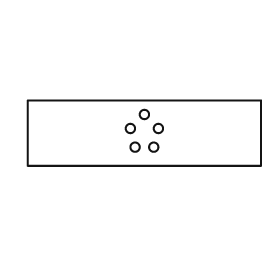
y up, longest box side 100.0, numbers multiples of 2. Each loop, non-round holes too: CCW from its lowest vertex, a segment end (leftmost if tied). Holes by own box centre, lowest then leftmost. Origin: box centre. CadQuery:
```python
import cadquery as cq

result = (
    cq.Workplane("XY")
    .moveTo(-50.0, -14.0)
    .lineTo(50.0, -14.0)
    .lineTo(50.0, 14.0)
    .lineTo(-50.0, 14.0)
    .close()
    .moveTo(-4.0, -6.0)
    .circle(2.0)
    .moveTo(4.0, -6.0)
    .circle(2.0)
    .moveTo(-6.0, 2.0)
    .circle(2.0)
    .moveTo(6.0, 2.0)
    .circle(2.0)
    .moveTo(0.0, 8.0)
    .circle(2.0)
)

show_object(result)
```